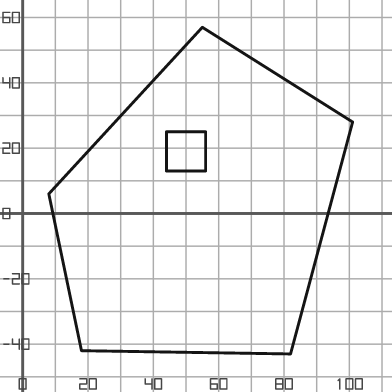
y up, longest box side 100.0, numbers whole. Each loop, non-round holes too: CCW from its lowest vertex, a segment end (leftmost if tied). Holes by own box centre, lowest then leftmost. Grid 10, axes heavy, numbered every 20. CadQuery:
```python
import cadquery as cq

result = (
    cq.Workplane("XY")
    .moveTo(82.0, -43.0)
    .lineTo(101.0, 28.0)
    .lineTo(55.0, 57.0)
    .lineTo(8.0, 6.0)
    .lineTo(18.0, -42.0)
    .close()
    .moveTo(44.0, 13.0)
    .lineTo(56.0, 13.0)
    .lineTo(56.0, 25.0)
    .lineTo(44.0, 25.0)
    .close()
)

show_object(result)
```